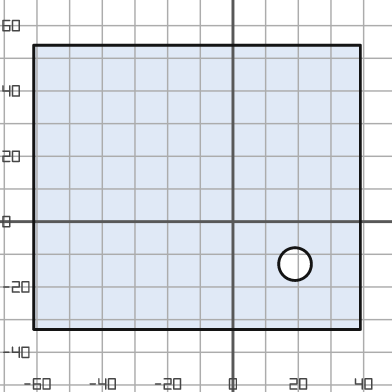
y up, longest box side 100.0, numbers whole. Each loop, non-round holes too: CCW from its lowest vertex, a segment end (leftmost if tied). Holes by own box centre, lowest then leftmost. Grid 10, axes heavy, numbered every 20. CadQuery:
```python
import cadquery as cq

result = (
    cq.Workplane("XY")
    .moveTo(-61.0, -33.0)
    .lineTo(39.0, -33.0)
    .lineTo(39.0, 54.0)
    .lineTo(-61.0, 54.0)
    .close()
    .moveTo(19.0, -13.0)
    .circle(5.0)
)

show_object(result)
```